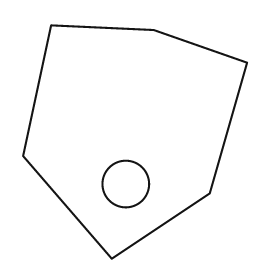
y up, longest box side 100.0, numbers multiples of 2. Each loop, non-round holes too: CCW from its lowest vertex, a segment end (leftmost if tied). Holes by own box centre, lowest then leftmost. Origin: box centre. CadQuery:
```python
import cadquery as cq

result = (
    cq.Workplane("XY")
    .moveTo(-10.0, -50.0)
    .lineTo(32.0, -22.0)
    .lineTo(48.0, 34.0)
    .lineTo(8.0, 48.0)
    .lineTo(-36.0, 50.0)
    .lineTo(-48.0, -6.0)
    .close()
    .moveTo(-4.0, -18.0)
    .circle(10.0)
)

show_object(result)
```